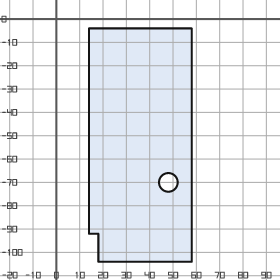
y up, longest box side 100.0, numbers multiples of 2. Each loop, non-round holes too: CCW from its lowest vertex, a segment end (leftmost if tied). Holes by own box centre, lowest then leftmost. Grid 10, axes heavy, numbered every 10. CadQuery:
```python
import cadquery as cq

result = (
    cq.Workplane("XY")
    .moveTo(18.0, -104.0)
    .lineTo(58.0, -104.0)
    .lineTo(58.0, -4.0)
    .lineTo(14.0, -4.0)
    .lineTo(14.0, -92.0)
    .lineTo(18.0, -92.0)
    .close()
    .moveTo(48.0, -70.0)
    .circle(4.0)
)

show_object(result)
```